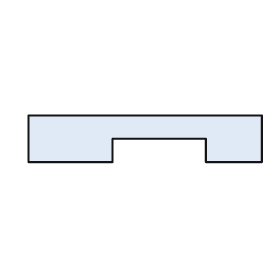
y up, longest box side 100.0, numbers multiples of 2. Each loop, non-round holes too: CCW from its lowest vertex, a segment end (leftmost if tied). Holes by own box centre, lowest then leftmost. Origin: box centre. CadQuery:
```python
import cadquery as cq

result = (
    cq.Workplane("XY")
    .moveTo(-50.0, -10.0)
    .lineTo(-14.0, -10.0)
    .lineTo(-14.0, 0.0)
    .lineTo(26.0, 0.0)
    .lineTo(26.0, -10.0)
    .lineTo(50.0, -10.0)
    .lineTo(50.0, 10.0)
    .lineTo(-50.0, 10.0)
    .close()
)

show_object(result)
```